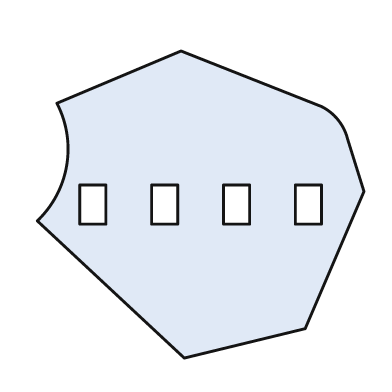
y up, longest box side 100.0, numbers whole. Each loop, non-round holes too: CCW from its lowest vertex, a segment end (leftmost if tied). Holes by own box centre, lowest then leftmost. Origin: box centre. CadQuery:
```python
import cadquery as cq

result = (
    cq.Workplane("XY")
    .moveTo(-5.0, -47.0)
    .lineTo(32.0, -38.0)
    .lineTo(50.0, 4.0)
    .lineTo(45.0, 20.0)
    .threePointArc((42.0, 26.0), (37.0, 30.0))
    .lineTo(-6.0, 47.0)
    .lineTo(-44.0, 31.0)
    .threePointArc((-41.0, 12.0), (-50.0, -5.0))
    .close()
    .moveTo(-37.0, -6.0)
    .lineTo(-29.0, -6.0)
    .lineTo(-29.0, 6.0)
    .lineTo(-37.0, 6.0)
    .close()
    .moveTo(-15.0, -6.0)
    .lineTo(-7.0, -6.0)
    .lineTo(-7.0, 6.0)
    .lineTo(-15.0, 6.0)
    .close()
    .moveTo(7.0, -6.0)
    .lineTo(15.0, -6.0)
    .lineTo(15.0, 6.0)
    .lineTo(7.0, 6.0)
    .close()
    .moveTo(29.0, -6.0)
    .lineTo(37.0, -6.0)
    .lineTo(37.0, 6.0)
    .lineTo(29.0, 6.0)
    .close()
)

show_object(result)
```